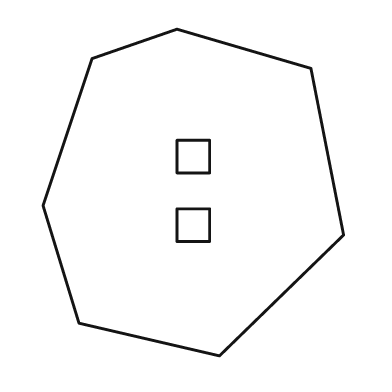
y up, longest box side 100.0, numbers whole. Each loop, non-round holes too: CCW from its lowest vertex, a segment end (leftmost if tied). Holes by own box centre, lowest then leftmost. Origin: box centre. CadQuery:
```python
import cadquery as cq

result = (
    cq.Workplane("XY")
    .moveTo(8.0, -50.0)
    .lineTo(46.0, -13.0)
    .lineTo(36.0, 38.0)
    .lineTo(-5.0, 50.0)
    .lineTo(-31.0, 41.0)
    .lineTo(-46.0, -4.0)
    .lineTo(-35.0, -40.0)
    .close()
    .moveTo(-5.0, -15.0)
    .lineTo(5.0, -15.0)
    .lineTo(5.0, -5.0)
    .lineTo(-5.0, -5.0)
    .close()
    .moveTo(-5.0, 6.0)
    .lineTo(5.0, 6.0)
    .lineTo(5.0, 16.0)
    .lineTo(-5.0, 16.0)
    .close()
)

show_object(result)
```